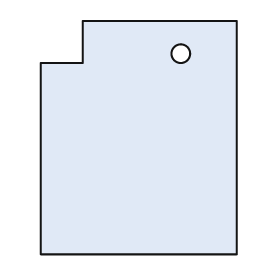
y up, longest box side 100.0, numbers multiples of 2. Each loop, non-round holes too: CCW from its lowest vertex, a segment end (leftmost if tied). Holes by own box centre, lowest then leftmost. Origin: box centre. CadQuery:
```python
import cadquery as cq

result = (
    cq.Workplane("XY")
    .moveTo(-42.0, -50.0)
    .lineTo(42.0, -50.0)
    .lineTo(42.0, 50.0)
    .lineTo(-24.0, 50.0)
    .lineTo(-24.0, 32.0)
    .lineTo(-42.0, 32.0)
    .close()
    .moveTo(18.0, 36.0)
    .circle(4.0)
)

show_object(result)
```